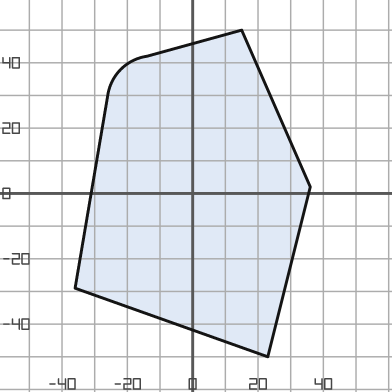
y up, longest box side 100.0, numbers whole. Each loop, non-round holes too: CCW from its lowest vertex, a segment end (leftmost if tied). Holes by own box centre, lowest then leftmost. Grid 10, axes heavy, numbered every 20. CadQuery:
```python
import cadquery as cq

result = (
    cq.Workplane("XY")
    .moveTo(23.0, -50.0)
    .lineTo(36.0, 2.0)
    .lineTo(15.0, 50.0)
    .lineTo(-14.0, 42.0)
    .threePointArc((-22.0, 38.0), (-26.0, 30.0))
    .lineTo(-36.0, -29.0)
    .close()
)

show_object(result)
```